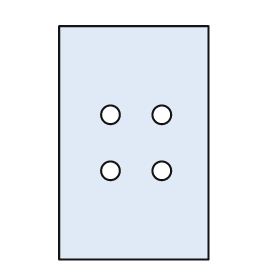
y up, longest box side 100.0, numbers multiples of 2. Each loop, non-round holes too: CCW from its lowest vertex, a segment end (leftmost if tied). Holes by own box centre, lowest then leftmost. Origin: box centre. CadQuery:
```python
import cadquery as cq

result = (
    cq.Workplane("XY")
    .moveTo(-32.0, -50.0)
    .lineTo(32.0, -50.0)
    .lineTo(32.0, 50.0)
    .lineTo(-32.0, 50.0)
    .close()
    .moveTo(-10.0, -12.0)
    .circle(4.0)
    .moveTo(12.0, -12.0)
    .circle(4.0)
    .moveTo(-10.0, 12.0)
    .circle(4.0)
    .moveTo(12.0, 12.0)
    .circle(4.0)
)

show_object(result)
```